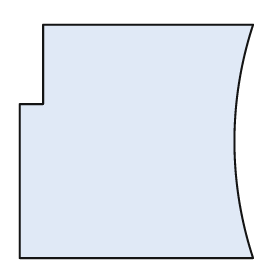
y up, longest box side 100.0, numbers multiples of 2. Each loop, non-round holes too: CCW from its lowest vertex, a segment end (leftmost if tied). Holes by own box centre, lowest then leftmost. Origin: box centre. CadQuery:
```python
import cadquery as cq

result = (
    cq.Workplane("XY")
    .moveTo(-50.0, -50.0)
    .lineTo(50.0, -50.0)
    .threePointArc((42.0, 0.0), (50.0, 50.0))
    .lineTo(-40.0, 50.0)
    .lineTo(-40.0, 16.0)
    .lineTo(-50.0, 16.0)
    .close()
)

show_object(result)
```